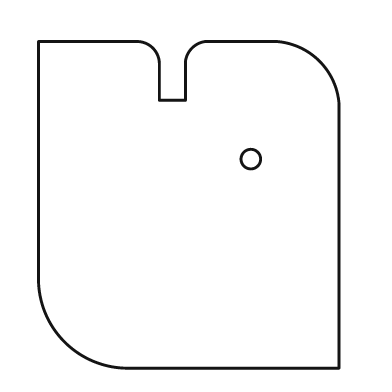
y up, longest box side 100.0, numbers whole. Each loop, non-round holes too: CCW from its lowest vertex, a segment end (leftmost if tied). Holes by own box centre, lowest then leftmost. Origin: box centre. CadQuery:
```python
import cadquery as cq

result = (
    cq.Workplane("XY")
    .moveTo(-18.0, -50.0)
    .lineTo(46.0, -50.0)
    .lineTo(46.0, 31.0)
    .threePointArc((40.0, 44.0), (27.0, 50.0))
    .lineTo(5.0, 50.0)
    .threePointArc((1.0, 48.0), (-1.0, 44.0))
    .lineTo(-1.0, 32.0)
    .lineTo(-9.0, 32.0)
    .lineTo(-9.0, 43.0)
    .threePointArc((-11.0, 48.0), (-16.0, 50.0))
    .lineTo(-46.0, 50.0)
    .lineTo(-46.0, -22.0)
    .threePointArc((-38.0, -42.0), (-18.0, -50.0))
    .close()
    .moveTo(19.0, 14.0)
    .circle(3.0)
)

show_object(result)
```